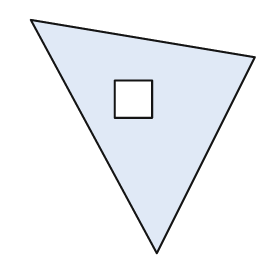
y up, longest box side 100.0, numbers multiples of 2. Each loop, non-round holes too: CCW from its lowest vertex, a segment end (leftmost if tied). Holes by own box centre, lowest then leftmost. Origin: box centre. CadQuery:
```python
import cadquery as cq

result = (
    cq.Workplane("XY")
    .moveTo(6.0, -50.0)
    .lineTo(48.0, 34.0)
    .lineTo(-48.0, 50.0)
    .close()
    .moveTo(-12.0, 8.0)
    .lineTo(4.0, 8.0)
    .lineTo(4.0, 24.0)
    .lineTo(-12.0, 24.0)
    .close()
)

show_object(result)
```